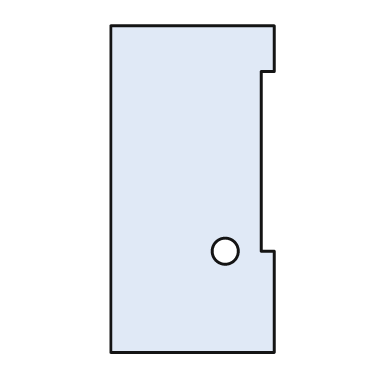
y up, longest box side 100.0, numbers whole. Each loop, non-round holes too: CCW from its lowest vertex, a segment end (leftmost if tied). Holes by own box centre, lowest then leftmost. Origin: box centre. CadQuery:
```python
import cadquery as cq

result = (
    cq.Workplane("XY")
    .moveTo(-25.0, -50.0)
    .lineTo(25.0, -50.0)
    .lineTo(25.0, -19.0)
    .lineTo(21.0, -19.0)
    .lineTo(21.0, 36.0)
    .lineTo(25.0, 36.0)
    .lineTo(25.0, 50.0)
    .lineTo(-25.0, 50.0)
    .close()
    .moveTo(10.0, -19.0)
    .circle(4.0)
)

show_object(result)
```